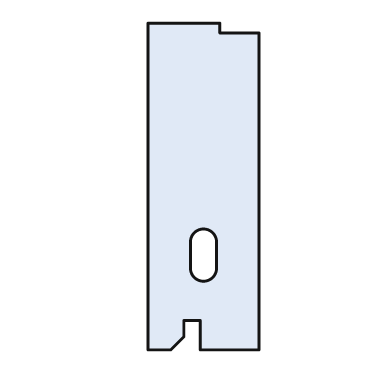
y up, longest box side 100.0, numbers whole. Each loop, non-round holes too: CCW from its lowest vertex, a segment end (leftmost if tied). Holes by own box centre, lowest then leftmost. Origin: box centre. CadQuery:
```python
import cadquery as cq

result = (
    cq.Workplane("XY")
    .moveTo(-17.0, -50.0)
    .lineTo(-10.0, -50.0)
    .lineTo(-6.0, -46.0)
    .lineTo(-6.0, -41.0)
    .lineTo(-1.0, -41.0)
    .lineTo(-1.0, -50.0)
    .lineTo(17.0, -50.0)
    .lineTo(17.0, 47.0)
    .lineTo(5.0, 47.0)
    .lineTo(5.0, 50.0)
    .lineTo(-17.0, 50.0)
    .close()
    .moveTo(-4.0, -25.0)
    .threePointArc((0.0, -29.0), (4.0, -25.0))
    .lineTo(4.0, -17.0)
    .threePointArc((0.0, -13.0), (-4.0, -17.0))
    .close()
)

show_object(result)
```